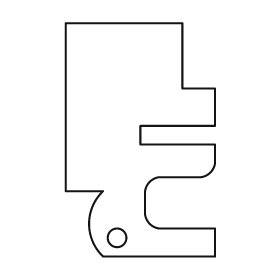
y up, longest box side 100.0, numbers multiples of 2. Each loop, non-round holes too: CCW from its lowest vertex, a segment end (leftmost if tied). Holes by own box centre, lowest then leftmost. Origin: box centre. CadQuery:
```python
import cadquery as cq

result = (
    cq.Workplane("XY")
    .moveTo(-16.0, -50.0)
    .lineTo(32.0, -50.0)
    .lineTo(32.0, -38.0)
    .lineTo(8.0, -38.0)
    .threePointArc((4.0, -36.0), (2.0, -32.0))
    .lineTo(2.0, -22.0)
    .threePointArc((4.0, -18.0), (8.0, -16.0))
    .lineTo(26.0, -16.0)
    .threePointArc((30.0, -14.0), (32.0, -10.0))
    .lineTo(32.0, -2.0)
    .lineTo(0.0, -2.0)
    .lineTo(0.0, 6.0)
    .lineTo(32.0, 6.0)
    .lineTo(32.0, 22.0)
    .lineTo(18.0, 22.0)
    .lineTo(18.0, 50.0)
    .lineTo(-32.0, 50.0)
    .lineTo(-32.0, -22.0)
    .lineTo(-16.0, -22.0)
    .threePointArc((-22.0, -36.0), (-16.0, -50.0))
    .close()
    .moveTo(-10.0, -42.0)
    .circle(4.0)
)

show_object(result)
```